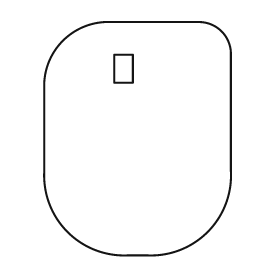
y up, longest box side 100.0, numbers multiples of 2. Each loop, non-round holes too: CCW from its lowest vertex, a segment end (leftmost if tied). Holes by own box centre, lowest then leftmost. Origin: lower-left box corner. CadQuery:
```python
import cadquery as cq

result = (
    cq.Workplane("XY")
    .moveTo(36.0, 0.0)
    .lineTo(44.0, 0.0)
    .threePointArc((70.0, 10.0), (80.0, 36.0))
    .lineTo(80.0, 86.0)
    .threePointArc((76.0, 96.0), (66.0, 100.0))
    .lineTo(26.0, 100.0)
    .threePointArc((8.0, 92.0), (0.0, 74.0))
    .lineTo(0.0, 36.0)
    .threePointArc((10.0, 10.0), (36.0, 0.0))
    .close()
    .moveTo(30.0, 74.0)
    .lineTo(38.0, 74.0)
    .lineTo(38.0, 86.0)
    .lineTo(30.0, 86.0)
    .close()
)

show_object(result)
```